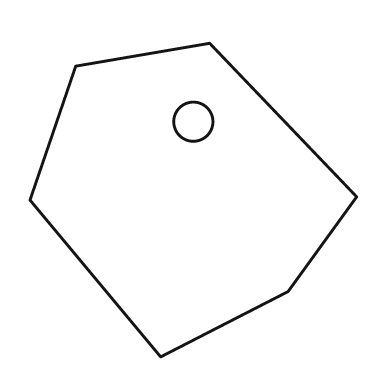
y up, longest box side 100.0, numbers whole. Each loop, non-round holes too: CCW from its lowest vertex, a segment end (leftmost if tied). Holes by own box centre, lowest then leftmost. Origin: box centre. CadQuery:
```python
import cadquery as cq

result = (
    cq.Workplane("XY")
    .moveTo(-10.0, -48.0)
    .lineTo(29.0, -28.0)
    .lineTo(50.0, 1.0)
    .lineTo(5.0, 48.0)
    .lineTo(-36.0, 41.0)
    .lineTo(-50.0, 0.0)
    .close()
    .moveTo(0.0, 24.0)
    .circle(6.0)
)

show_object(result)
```